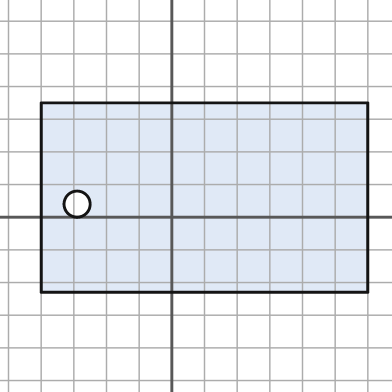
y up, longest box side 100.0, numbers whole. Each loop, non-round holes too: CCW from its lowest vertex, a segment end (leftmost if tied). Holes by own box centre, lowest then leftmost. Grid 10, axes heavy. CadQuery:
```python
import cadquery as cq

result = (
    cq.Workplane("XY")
    .moveTo(-40.0, -23.0)
    .lineTo(60.0, -23.0)
    .lineTo(60.0, 35.0)
    .lineTo(-40.0, 35.0)
    .close()
    .moveTo(-29.0, 4.0)
    .circle(4.0)
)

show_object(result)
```